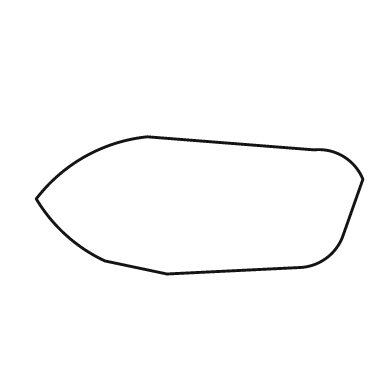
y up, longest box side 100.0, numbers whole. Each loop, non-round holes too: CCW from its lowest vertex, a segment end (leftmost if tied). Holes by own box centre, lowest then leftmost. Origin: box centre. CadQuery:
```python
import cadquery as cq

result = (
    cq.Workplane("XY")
    .moveTo(-10.0, -21.0)
    .lineTo(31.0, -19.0)
    .threePointArc((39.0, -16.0), (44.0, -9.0))
    .lineTo(50.0, 8.0)
    .threePointArc((44.0, 15.0), (35.0, 17.0))
    .lineTo(-16.0, 21.0)
    .threePointArc((-35.0, 15.0), (-50.0, 2.0))
    .threePointArc((-41.0, -9.0), (-29.0, -17.0))
    .close()
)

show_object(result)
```